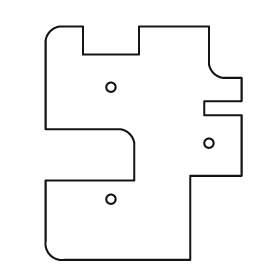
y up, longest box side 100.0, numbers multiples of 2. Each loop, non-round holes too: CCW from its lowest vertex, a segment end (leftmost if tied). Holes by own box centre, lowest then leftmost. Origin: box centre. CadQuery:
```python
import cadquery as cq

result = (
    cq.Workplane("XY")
    .moveTo(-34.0, -50.0)
    .lineTo(20.0, -50.0)
    .lineTo(20.0, -14.0)
    .lineTo(42.0, -14.0)
    .lineTo(42.0, 12.0)
    .lineTo(26.0, 12.0)
    .lineTo(26.0, 18.0)
    .lineTo(42.0, 18.0)
    .lineTo(42.0, 28.0)
    .lineTo(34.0, 28.0)
    .threePointArc((30.0, 30.0), (28.0, 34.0))
    .lineTo(28.0, 50.0)
    .lineTo(-2.0, 50.0)
    .lineTo(-2.0, 38.0)
    .lineTo(-26.0, 38.0)
    .lineTo(-26.0, 50.0)
    .lineTo(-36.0, 50.0)
    .threePointArc((-40.0, 48.0), (-42.0, 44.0))
    .lineTo(-42.0, 6.0)
    .lineTo(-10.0, 6.0)
    .threePointArc((-6.0, 4.0), (-4.0, 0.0))
    .lineTo(-4.0, -16.0)
    .lineTo(-42.0, -16.0)
    .lineTo(-42.0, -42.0)
    .threePointArc((-40.0, -48.0), (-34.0, -50.0))
    .close()
    .moveTo(-14.0, -24.0)
    .circle(2.0)
    .moveTo(28.0, 0.0)
    .circle(2.0)
    .moveTo(-14.0, 24.0)
    .circle(2.0)
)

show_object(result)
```